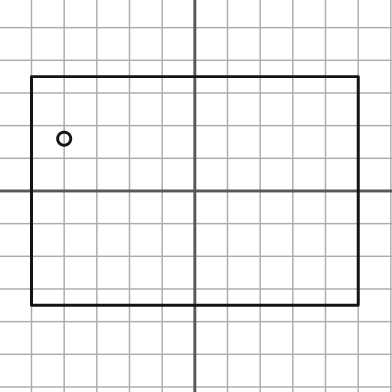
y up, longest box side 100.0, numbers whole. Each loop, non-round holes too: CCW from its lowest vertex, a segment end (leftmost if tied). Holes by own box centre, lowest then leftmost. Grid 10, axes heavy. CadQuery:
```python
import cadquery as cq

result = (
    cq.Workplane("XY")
    .moveTo(-50.0, -35.0)
    .lineTo(50.0, -35.0)
    .lineTo(50.0, 35.0)
    .lineTo(-50.0, 35.0)
    .close()
    .moveTo(-40.0, 16.0)
    .circle(2.0)
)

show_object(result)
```